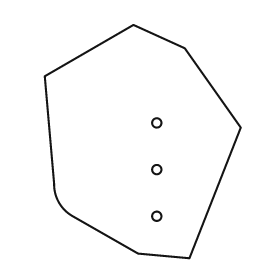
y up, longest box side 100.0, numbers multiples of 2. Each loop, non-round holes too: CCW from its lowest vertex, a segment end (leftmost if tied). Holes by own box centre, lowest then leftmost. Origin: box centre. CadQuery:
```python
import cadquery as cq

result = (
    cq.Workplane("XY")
    .moveTo(20.0, -50.0)
    .lineTo(42.0, 6.0)
    .lineTo(18.0, 40.0)
    .lineTo(-4.0, 50.0)
    .lineTo(-42.0, 28.0)
    .lineTo(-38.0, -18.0)
    .threePointArc((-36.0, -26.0), (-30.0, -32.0))
    .lineTo(-2.0, -48.0)
    .close()
    .moveTo(6.0, -32.0)
    .circle(2.0)
    .moveTo(6.0, -12.0)
    .circle(2.0)
    .moveTo(6.0, 8.0)
    .circle(2.0)
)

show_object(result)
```